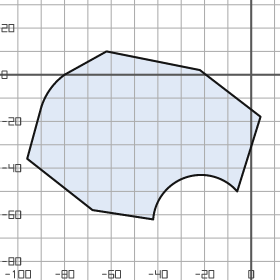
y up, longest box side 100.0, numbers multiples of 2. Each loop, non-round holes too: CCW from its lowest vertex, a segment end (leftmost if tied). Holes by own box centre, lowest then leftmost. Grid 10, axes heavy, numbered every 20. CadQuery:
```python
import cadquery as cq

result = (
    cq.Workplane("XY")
    .moveTo(-42.0, -62.0)
    .threePointArc((-28.0, -44.0), (-6.0, -50.0))
    .lineTo(4.0, -18.0)
    .lineTo(-22.0, 2.0)
    .lineTo(-62.0, 10.0)
    .lineTo(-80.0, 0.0)
    .threePointArc((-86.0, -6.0), (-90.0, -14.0))
    .lineTo(-96.0, -36.0)
    .lineTo(-68.0, -58.0)
    .close()
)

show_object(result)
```